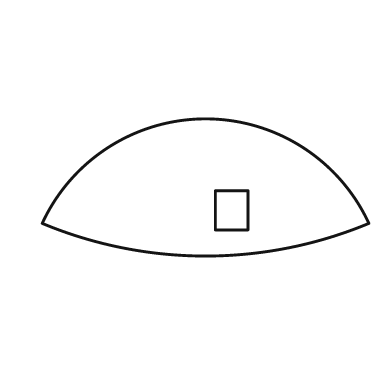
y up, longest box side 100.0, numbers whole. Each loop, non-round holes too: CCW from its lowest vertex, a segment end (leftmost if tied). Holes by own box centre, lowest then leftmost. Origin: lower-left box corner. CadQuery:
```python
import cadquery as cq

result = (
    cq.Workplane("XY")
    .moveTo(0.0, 10.0)
    .threePointArc((50.0, 0.0), (100.0, 10.0))
    .threePointArc((50.0, 42.0), (0.0, 10.0))
    .close()
    .moveTo(53.0, 8.0)
    .lineTo(63.0, 8.0)
    .lineTo(63.0, 20.0)
    .lineTo(53.0, 20.0)
    .close()
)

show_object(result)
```